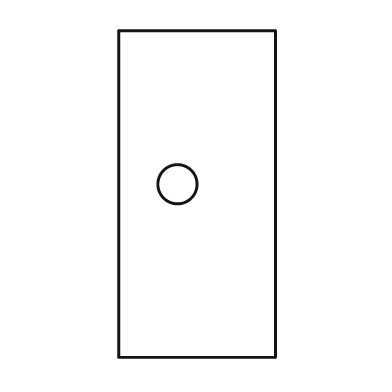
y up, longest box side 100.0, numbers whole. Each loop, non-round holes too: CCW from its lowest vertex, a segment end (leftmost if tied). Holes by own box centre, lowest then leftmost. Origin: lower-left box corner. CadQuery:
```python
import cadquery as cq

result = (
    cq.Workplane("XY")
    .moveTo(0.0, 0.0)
    .lineTo(48.0, 0.0)
    .lineTo(48.0, 100.0)
    .lineTo(0.0, 100.0)
    .close()
    .moveTo(18.0, 53.0)
    .circle(6.0)
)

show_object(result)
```